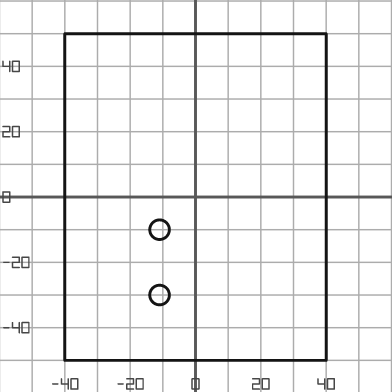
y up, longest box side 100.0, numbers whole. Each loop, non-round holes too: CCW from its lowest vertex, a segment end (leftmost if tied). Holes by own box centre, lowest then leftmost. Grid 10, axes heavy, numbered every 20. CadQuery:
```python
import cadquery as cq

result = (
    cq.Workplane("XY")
    .moveTo(-40.0, -50.0)
    .lineTo(40.0, -50.0)
    .lineTo(40.0, 50.0)
    .lineTo(-40.0, 50.0)
    .close()
    .moveTo(-11.0, -30.0)
    .circle(3.0)
    .moveTo(-11.0, -10.0)
    .circle(3.0)
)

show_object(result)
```